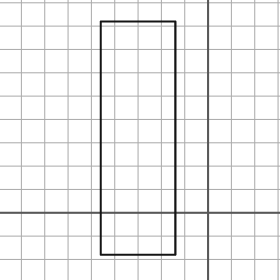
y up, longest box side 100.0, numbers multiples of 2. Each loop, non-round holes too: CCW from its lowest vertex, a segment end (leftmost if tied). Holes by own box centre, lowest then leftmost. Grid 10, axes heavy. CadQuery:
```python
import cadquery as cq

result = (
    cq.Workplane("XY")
    .moveTo(-46.0, -18.0)
    .lineTo(-14.0, -18.0)
    .lineTo(-14.0, 82.0)
    .lineTo(-46.0, 82.0)
    .close()
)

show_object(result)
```